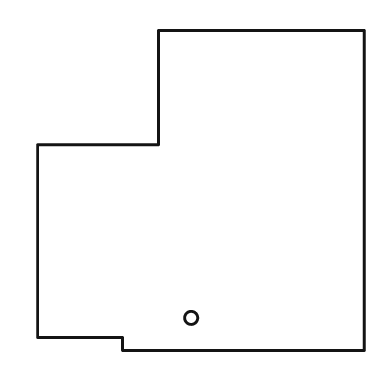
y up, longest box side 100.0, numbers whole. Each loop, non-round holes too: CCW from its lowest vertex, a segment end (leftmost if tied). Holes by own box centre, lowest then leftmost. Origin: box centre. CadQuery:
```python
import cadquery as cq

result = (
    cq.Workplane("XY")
    .moveTo(-24.0, -49.0)
    .lineTo(50.0, -49.0)
    .lineTo(50.0, 49.0)
    .lineTo(-13.0, 49.0)
    .lineTo(-13.0, 14.0)
    .lineTo(-50.0, 14.0)
    .lineTo(-50.0, -45.0)
    .lineTo(-24.0, -45.0)
    .close()
    .moveTo(-3.0, -39.0)
    .circle(2.0)
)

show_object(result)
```